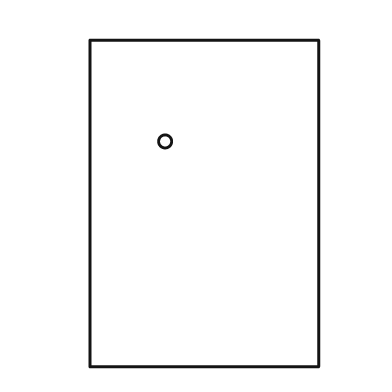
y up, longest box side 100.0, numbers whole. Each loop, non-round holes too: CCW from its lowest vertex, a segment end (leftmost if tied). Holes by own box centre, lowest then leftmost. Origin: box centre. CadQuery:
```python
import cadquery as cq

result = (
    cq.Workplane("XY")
    .moveTo(-35.0, -50.0)
    .lineTo(35.0, -50.0)
    .lineTo(35.0, 50.0)
    .lineTo(-35.0, 50.0)
    .close()
    .moveTo(-12.0, 19.0)
    .circle(2.0)
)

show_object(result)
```